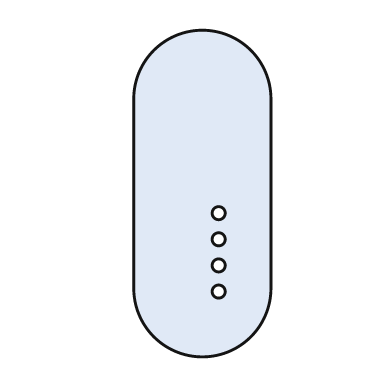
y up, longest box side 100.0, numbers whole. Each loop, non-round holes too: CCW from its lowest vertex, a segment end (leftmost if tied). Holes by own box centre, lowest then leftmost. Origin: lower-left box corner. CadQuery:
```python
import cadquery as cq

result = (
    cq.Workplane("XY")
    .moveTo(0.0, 21.0)
    .threePointArc((21.0, 0.0), (42.0, 21.0))
    .lineTo(42.0, 79.0)
    .threePointArc((21.0, 100.0), (0.0, 79.0))
    .close()
    .moveTo(26.0, 20.0)
    .circle(2.0)
    .moveTo(26.0, 28.0)
    .circle(2.0)
    .moveTo(26.0, 36.0)
    .circle(2.0)
    .moveTo(26.0, 44.0)
    .circle(2.0)
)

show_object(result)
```